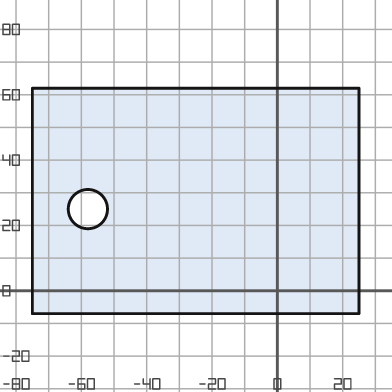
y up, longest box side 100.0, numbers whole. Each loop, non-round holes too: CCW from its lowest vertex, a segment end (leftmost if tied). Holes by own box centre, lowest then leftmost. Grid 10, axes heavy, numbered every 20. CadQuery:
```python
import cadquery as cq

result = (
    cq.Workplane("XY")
    .moveTo(-75.0, -7.0)
    .lineTo(25.0, -7.0)
    .lineTo(25.0, 62.0)
    .lineTo(-75.0, 62.0)
    .close()
    .moveTo(-58.0, 25.0)
    .circle(6.0)
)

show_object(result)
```